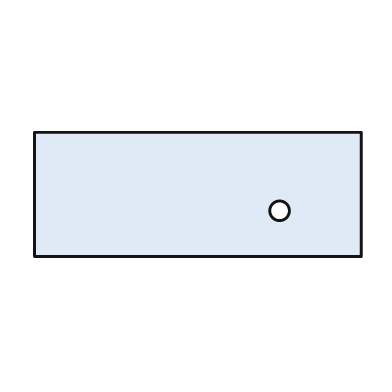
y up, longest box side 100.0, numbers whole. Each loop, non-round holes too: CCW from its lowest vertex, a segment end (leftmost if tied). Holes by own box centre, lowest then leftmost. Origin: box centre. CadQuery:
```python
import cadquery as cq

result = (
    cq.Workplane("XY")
    .moveTo(-50.0, -19.0)
    .lineTo(50.0, -19.0)
    .lineTo(50.0, 19.0)
    .lineTo(-50.0, 19.0)
    .close()
    .moveTo(25.0, -5.0)
    .circle(3.0)
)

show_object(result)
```